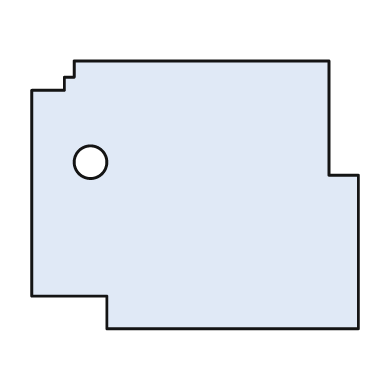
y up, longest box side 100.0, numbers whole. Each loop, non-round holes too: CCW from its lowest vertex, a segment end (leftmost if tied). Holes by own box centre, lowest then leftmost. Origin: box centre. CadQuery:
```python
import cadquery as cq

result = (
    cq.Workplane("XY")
    .moveTo(-27.0, -41.0)
    .lineTo(50.0, -41.0)
    .lineTo(50.0, 6.0)
    .lineTo(41.0, 6.0)
    .lineTo(41.0, 41.0)
    .lineTo(-37.0, 41.0)
    .lineTo(-37.0, 36.0)
    .lineTo(-40.0, 36.0)
    .lineTo(-40.0, 32.0)
    .lineTo(-50.0, 32.0)
    .lineTo(-50.0, -31.0)
    .lineTo(-27.0, -31.0)
    .close()
    .moveTo(-32.0, 10.0)
    .circle(5.0)
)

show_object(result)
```